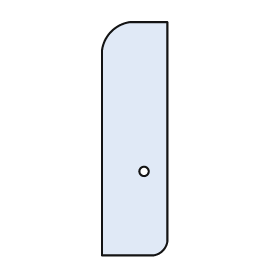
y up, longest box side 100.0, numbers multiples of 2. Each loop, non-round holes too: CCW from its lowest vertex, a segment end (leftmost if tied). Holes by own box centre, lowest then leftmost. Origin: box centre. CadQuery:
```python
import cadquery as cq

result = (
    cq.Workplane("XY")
    .moveTo(-14.0, -50.0)
    .lineTo(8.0, -50.0)
    .threePointArc((12.0, -48.0), (14.0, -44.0))
    .lineTo(14.0, 50.0)
    .lineTo(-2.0, 50.0)
    .threePointArc((-10.0, 46.0), (-14.0, 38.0))
    .close()
    .moveTo(4.0, -14.0)
    .circle(2.0)
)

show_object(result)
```